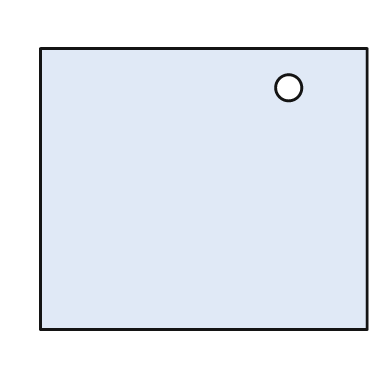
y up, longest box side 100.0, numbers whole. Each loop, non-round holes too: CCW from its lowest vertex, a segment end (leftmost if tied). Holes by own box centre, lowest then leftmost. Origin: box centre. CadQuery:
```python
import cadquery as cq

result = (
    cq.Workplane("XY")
    .moveTo(-50.0, -43.0)
    .lineTo(50.0, -43.0)
    .lineTo(50.0, 43.0)
    .lineTo(-50.0, 43.0)
    .close()
    .moveTo(26.0, 31.0)
    .circle(4.0)
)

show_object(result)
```